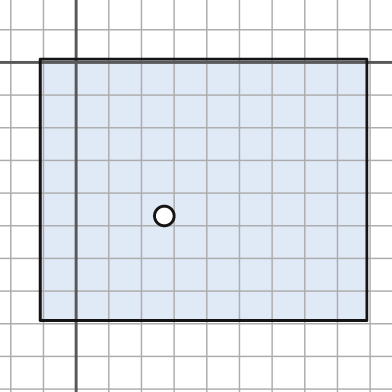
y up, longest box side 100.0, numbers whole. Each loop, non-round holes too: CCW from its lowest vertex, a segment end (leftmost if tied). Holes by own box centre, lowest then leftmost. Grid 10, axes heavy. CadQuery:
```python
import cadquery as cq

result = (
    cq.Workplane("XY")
    .moveTo(-11.0, -79.0)
    .lineTo(89.0, -79.0)
    .lineTo(89.0, 1.0)
    .lineTo(-11.0, 1.0)
    .close()
    .moveTo(27.0, -47.0)
    .circle(3.0)
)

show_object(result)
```